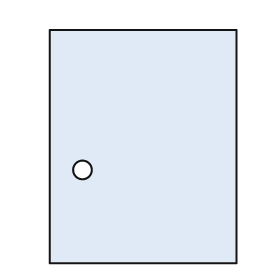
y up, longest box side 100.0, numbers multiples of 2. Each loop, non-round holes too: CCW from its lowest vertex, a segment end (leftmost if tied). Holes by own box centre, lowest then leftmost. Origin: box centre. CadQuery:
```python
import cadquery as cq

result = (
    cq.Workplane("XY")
    .moveTo(-40.0, -50.0)
    .lineTo(40.0, -50.0)
    .lineTo(40.0, 50.0)
    .lineTo(-40.0, 50.0)
    .close()
    .moveTo(-26.0, -10.0)
    .circle(4.0)
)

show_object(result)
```